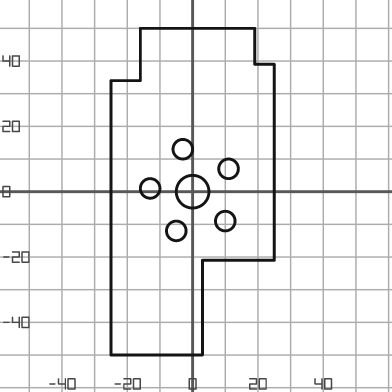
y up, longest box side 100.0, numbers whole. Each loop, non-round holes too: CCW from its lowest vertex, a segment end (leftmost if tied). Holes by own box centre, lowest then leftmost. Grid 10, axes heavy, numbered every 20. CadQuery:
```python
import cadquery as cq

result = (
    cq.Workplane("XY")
    .moveTo(-25.0, -50.0)
    .lineTo(3.0, -50.0)
    .lineTo(3.0, -21.0)
    .lineTo(25.0, -21.0)
    .lineTo(25.0, 39.0)
    .lineTo(19.0, 39.0)
    .lineTo(19.0, 50.0)
    .lineTo(-16.0, 50.0)
    .lineTo(-16.0, 34.0)
    .lineTo(-25.0, 34.0)
    .close()
    .moveTo(-5.0, -12.0)
    .circle(3.0)
    .moveTo(10.0, -9.0)
    .circle(3.0)
    .moveTo(0.0, 0.0)
    .circle(5.0)
    .moveTo(-13.0, 1.0)
    .circle(3.0)
    .moveTo(11.0, 7.0)
    .circle(3.0)
    .moveTo(-3.0, 13.0)
    .circle(3.0)
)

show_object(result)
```